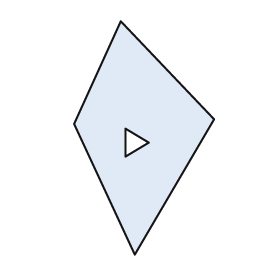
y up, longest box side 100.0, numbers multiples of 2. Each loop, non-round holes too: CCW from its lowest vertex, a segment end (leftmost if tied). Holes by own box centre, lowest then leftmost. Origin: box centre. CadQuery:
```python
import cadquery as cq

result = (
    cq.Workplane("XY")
    .moveTo(-4.0, -50.0)
    .lineTo(30.0, 8.0)
    .lineTo(-10.0, 50.0)
    .lineTo(-30.0, 6.0)
    .close()
    .moveTo(-8.0, -8.0)
    .lineTo(2.0, -2.0)
    .lineTo(-8.0, 4.0)
    .close()
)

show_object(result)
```